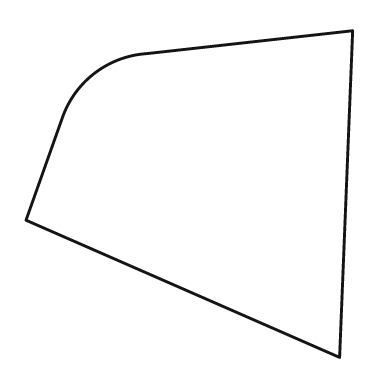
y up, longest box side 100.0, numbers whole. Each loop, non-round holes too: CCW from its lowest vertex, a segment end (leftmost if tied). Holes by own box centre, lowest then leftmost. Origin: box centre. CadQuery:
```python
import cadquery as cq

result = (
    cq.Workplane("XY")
    .moveTo(46.0, -50.0)
    .lineTo(50.0, 50.0)
    .lineTo(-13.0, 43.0)
    .threePointArc((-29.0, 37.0), (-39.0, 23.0))
    .lineTo(-50.0, -8.0)
    .close()
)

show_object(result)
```